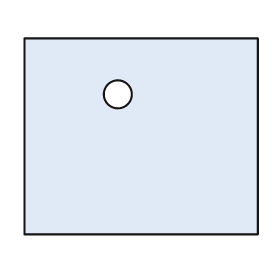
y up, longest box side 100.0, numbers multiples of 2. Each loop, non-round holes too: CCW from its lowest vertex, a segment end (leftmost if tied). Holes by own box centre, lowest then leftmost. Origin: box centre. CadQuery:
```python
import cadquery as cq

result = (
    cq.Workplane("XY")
    .moveTo(-50.0, -42.0)
    .lineTo(50.0, -42.0)
    .lineTo(50.0, 42.0)
    .lineTo(-50.0, 42.0)
    .close()
    .moveTo(-10.0, 18.0)
    .circle(6.0)
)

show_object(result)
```